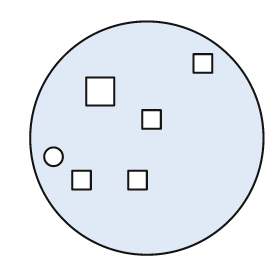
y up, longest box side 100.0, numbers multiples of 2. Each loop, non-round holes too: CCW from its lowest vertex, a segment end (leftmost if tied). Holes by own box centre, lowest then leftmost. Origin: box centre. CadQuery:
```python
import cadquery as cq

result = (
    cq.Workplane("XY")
    .moveTo(0.0, 0.0)
    .circle(50.0)
    .moveTo(-32.0, -22.0)
    .lineTo(-24.0, -22.0)
    .lineTo(-24.0, -14.0)
    .lineTo(-32.0, -14.0)
    .close()
    .moveTo(-8.0, -22.0)
    .lineTo(0.0, -22.0)
    .lineTo(0.0, -14.0)
    .lineTo(-8.0, -14.0)
    .close()
    .moveTo(-40.0, -8.0)
    .circle(4.0)
    .moveTo(-2.0, 4.0)
    .lineTo(6.0, 4.0)
    .lineTo(6.0, 12.0)
    .lineTo(-2.0, 12.0)
    .close()
    .moveTo(-26.0, 14.0)
    .lineTo(-14.0, 14.0)
    .lineTo(-14.0, 26.0)
    .lineTo(-26.0, 26.0)
    .close()
    .moveTo(20.0, 28.0)
    .lineTo(28.0, 28.0)
    .lineTo(28.0, 36.0)
    .lineTo(20.0, 36.0)
    .close()
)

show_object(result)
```